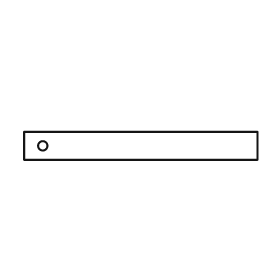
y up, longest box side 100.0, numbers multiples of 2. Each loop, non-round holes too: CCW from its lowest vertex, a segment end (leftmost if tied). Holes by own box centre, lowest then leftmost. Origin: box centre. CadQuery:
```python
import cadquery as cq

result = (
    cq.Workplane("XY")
    .moveTo(-50.0, -6.0)
    .lineTo(50.0, -6.0)
    .lineTo(50.0, 6.0)
    .lineTo(-50.0, 6.0)
    .close()
    .moveTo(-42.0, 0.0)
    .circle(2.0)
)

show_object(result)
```